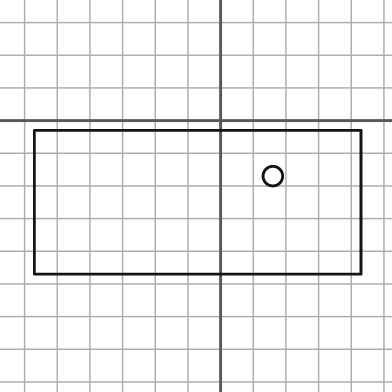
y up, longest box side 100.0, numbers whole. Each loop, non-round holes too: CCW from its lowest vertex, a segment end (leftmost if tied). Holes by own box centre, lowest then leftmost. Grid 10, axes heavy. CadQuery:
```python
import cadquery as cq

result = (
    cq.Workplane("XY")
    .moveTo(-57.0, -47.0)
    .lineTo(43.0, -47.0)
    .lineTo(43.0, -3.0)
    .lineTo(-57.0, -3.0)
    .close()
    .moveTo(16.0, -17.0)
    .circle(3.0)
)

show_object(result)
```